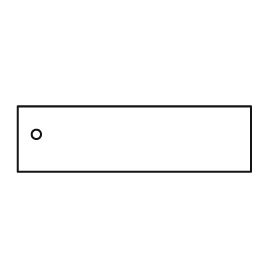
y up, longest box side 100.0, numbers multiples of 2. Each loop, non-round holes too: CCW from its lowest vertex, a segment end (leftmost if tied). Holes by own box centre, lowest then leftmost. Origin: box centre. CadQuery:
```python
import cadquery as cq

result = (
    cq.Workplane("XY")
    .moveTo(-50.0, -14.0)
    .lineTo(50.0, -14.0)
    .lineTo(50.0, 14.0)
    .lineTo(-50.0, 14.0)
    .close()
    .moveTo(-42.0, 2.0)
    .circle(2.0)
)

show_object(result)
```